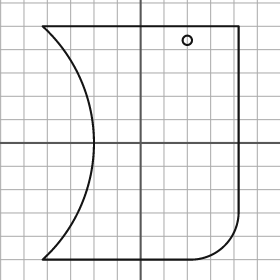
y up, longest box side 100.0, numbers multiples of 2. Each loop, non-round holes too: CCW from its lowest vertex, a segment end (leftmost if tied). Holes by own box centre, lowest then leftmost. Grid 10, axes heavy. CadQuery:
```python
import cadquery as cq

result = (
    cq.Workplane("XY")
    .moveTo(-42.0, -50.0)
    .lineTo(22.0, -50.0)
    .threePointArc((36.0, -44.0), (42.0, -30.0))
    .lineTo(42.0, 50.0)
    .lineTo(-42.0, 50.0)
    .threePointArc((-20.0, 0.0), (-42.0, -50.0))
    .close()
    .moveTo(20.0, 44.0)
    .circle(2.0)
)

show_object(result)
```